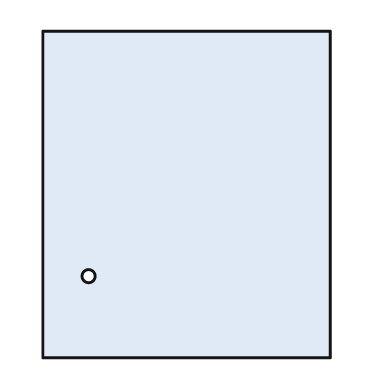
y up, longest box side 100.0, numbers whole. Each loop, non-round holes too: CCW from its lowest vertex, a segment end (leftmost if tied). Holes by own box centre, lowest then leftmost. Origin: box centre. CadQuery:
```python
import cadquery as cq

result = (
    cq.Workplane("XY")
    .moveTo(-44.0, -50.0)
    .lineTo(44.0, -50.0)
    .lineTo(44.0, 50.0)
    .lineTo(-44.0, 50.0)
    .close()
    .moveTo(-30.0, -25.0)
    .circle(2.0)
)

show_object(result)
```